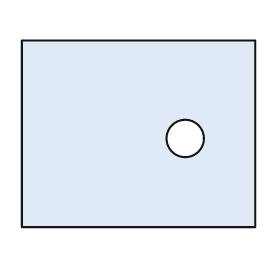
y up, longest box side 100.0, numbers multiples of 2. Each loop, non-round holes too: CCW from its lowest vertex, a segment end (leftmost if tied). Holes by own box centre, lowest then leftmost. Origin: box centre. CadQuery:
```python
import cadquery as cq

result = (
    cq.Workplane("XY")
    .moveTo(-50.0, -40.0)
    .lineTo(50.0, -40.0)
    .lineTo(50.0, 40.0)
    .lineTo(-50.0, 40.0)
    .close()
    .moveTo(20.0, -2.0)
    .circle(8.0)
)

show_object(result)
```